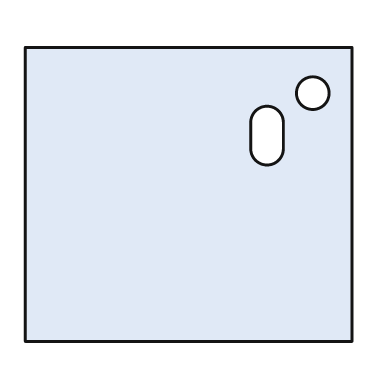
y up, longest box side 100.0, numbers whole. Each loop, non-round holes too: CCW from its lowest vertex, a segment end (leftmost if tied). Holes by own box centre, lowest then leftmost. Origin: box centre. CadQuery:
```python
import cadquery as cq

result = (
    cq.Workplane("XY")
    .moveTo(-50.0, -45.0)
    .lineTo(50.0, -45.0)
    .lineTo(50.0, 45.0)
    .lineTo(-50.0, 45.0)
    .close()
    .moveTo(19.0, 14.0)
    .threePointArc((24.0, 9.0), (29.0, 14.0))
    .lineTo(29.0, 22.0)
    .threePointArc((24.0, 27.0), (19.0, 22.0))
    .close()
    .moveTo(38.0, 31.0)
    .circle(5.0)
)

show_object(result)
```